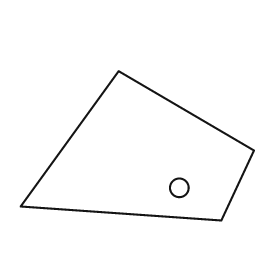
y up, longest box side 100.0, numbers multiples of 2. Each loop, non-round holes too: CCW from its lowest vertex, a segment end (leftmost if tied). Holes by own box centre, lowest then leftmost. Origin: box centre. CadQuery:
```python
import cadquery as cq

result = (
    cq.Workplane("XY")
    .moveTo(36.0, -32.0)
    .lineTo(50.0, -2.0)
    .lineTo(-8.0, 32.0)
    .lineTo(-50.0, -26.0)
    .close()
    .moveTo(18.0, -18.0)
    .circle(4.0)
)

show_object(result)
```